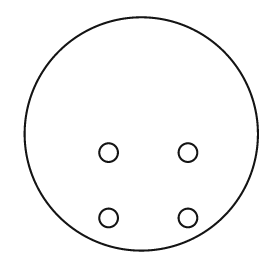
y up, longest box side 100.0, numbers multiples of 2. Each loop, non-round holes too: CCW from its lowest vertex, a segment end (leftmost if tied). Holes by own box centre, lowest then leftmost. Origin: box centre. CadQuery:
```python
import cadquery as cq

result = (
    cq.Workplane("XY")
    .moveTo(0.0, 0.0)
    .circle(50.0)
    .moveTo(-14.0, -36.0)
    .circle(4.0)
    .moveTo(20.0, -36.0)
    .circle(4.0)
    .moveTo(-14.0, -8.0)
    .circle(4.0)
    .moveTo(20.0, -8.0)
    .circle(4.0)
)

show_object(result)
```